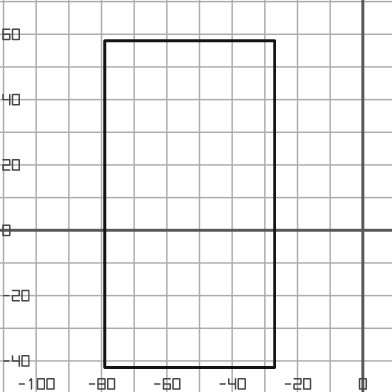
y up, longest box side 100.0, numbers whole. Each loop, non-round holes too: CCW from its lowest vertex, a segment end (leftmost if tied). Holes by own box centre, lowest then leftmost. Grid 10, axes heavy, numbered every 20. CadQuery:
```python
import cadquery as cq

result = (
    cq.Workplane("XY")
    .moveTo(-79.0, -42.0)
    .lineTo(-27.0, -42.0)
    .lineTo(-27.0, 58.0)
    .lineTo(-79.0, 58.0)
    .close()
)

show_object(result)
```